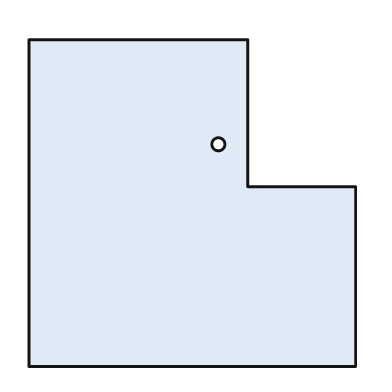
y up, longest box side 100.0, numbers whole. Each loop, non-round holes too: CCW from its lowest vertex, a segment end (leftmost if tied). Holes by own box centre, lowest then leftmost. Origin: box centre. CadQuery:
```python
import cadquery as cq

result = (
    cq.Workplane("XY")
    .moveTo(-50.0, -50.0)
    .lineTo(50.0, -50.0)
    .lineTo(50.0, 5.0)
    .lineTo(17.0, 5.0)
    .lineTo(17.0, 50.0)
    .lineTo(-50.0, 50.0)
    .close()
    .moveTo(8.0, 18.0)
    .circle(2.0)
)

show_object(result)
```